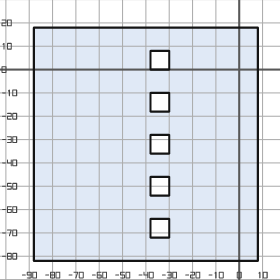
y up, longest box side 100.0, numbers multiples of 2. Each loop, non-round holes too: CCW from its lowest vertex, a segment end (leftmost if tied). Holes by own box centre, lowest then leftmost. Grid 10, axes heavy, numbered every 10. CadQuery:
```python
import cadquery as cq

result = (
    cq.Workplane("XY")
    .moveTo(-88.0, -82.0)
    .lineTo(8.0, -82.0)
    .lineTo(8.0, 18.0)
    .lineTo(-88.0, 18.0)
    .close()
    .moveTo(-38.0, -72.0)
    .lineTo(-30.0, -72.0)
    .lineTo(-30.0, -64.0)
    .lineTo(-38.0, -64.0)
    .close()
    .moveTo(-38.0, -54.0)
    .lineTo(-30.0, -54.0)
    .lineTo(-30.0, -46.0)
    .lineTo(-38.0, -46.0)
    .close()
    .moveTo(-38.0, -36.0)
    .lineTo(-30.0, -36.0)
    .lineTo(-30.0, -28.0)
    .lineTo(-38.0, -28.0)
    .close()
    .moveTo(-38.0, -18.0)
    .lineTo(-30.0, -18.0)
    .lineTo(-30.0, -10.0)
    .lineTo(-38.0, -10.0)
    .close()
    .moveTo(-38.0, 0.0)
    .lineTo(-30.0, 0.0)
    .lineTo(-30.0, 8.0)
    .lineTo(-38.0, 8.0)
    .close()
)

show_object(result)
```